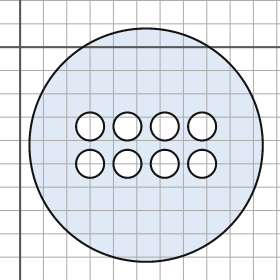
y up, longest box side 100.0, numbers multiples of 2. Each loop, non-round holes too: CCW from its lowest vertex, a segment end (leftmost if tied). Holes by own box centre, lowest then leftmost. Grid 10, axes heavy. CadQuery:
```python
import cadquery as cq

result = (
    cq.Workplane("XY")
    .moveTo(54.0, -42.0)
    .circle(50.0)
    .moveTo(30.0, -50.0)
    .circle(6.0)
    .moveTo(46.0, -50.0)
    .circle(6.0)
    .moveTo(62.0, -50.0)
    .circle(6.0)
    .moveTo(78.0, -50.0)
    .circle(6.0)
    .moveTo(30.0, -34.0)
    .circle(6.0)
    .moveTo(46.0, -34.0)
    .circle(6.0)
    .moveTo(62.0, -34.0)
    .circle(6.0)
    .moveTo(78.0, -34.0)
    .circle(6.0)
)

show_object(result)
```